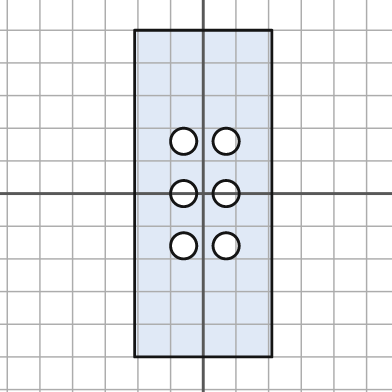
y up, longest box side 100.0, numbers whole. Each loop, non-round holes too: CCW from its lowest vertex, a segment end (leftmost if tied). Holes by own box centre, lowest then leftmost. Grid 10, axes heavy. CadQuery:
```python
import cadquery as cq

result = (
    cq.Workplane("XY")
    .moveTo(-21.0, -50.0)
    .lineTo(21.0, -50.0)
    .lineTo(21.0, 50.0)
    .lineTo(-21.0, 50.0)
    .close()
    .moveTo(-6.0, -16.0)
    .circle(4.0)
    .moveTo(7.0, -16.0)
    .circle(4.0)
    .moveTo(-6.0, 0.0)
    .circle(4.0)
    .moveTo(7.0, 0.0)
    .circle(4.0)
    .moveTo(-6.0, 16.0)
    .circle(4.0)
    .moveTo(7.0, 16.0)
    .circle(4.0)
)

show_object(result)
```